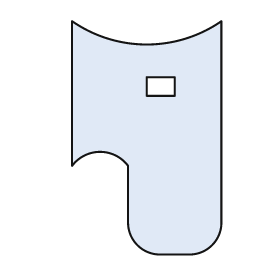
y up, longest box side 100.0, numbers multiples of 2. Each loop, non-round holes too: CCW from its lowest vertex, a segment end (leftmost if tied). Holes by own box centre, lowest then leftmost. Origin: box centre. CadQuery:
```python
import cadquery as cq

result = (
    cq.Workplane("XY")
    .moveTo(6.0, -50.0)
    .lineTo(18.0, -50.0)
    .threePointArc((28.0, -46.0), (32.0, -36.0))
    .lineTo(32.0, 50.0)
    .threePointArc((0.0, 40.0), (-32.0, 50.0))
    .lineTo(-32.0, -12.0)
    .threePointArc((-20.0, -6.0), (-8.0, -12.0))
    .lineTo(-8.0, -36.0)
    .threePointArc((-4.0, -46.0), (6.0, -50.0))
    .close()
    .moveTo(0.0, 18.0)
    .lineTo(12.0, 18.0)
    .lineTo(12.0, 26.0)
    .lineTo(0.0, 26.0)
    .close()
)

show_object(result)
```